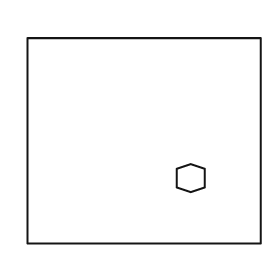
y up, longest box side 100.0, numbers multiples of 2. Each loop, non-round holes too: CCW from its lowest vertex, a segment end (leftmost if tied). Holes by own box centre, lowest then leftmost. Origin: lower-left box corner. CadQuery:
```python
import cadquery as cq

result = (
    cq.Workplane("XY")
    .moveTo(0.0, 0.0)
    .lineTo(100.0, 0.0)
    .lineTo(100.0, 88.0)
    .lineTo(0.0, 88.0)
    .close()
    .moveTo(70.0, 22.0)
    .lineTo(76.0, 24.0)
    .lineTo(76.0, 32.0)
    .lineTo(70.0, 34.0)
    .lineTo(64.0, 32.0)
    .lineTo(64.0, 24.0)
    .close()
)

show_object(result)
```